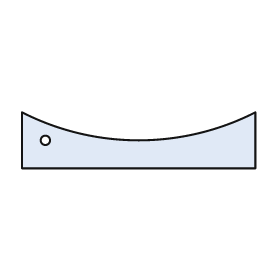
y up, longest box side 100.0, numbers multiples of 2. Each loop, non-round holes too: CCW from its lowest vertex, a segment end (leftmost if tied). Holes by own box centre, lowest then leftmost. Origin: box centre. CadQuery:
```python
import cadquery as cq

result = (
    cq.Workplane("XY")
    .moveTo(-50.0, -12.0)
    .lineTo(50.0, -12.0)
    .lineTo(50.0, 12.0)
    .threePointArc((0.0, 0.0), (-50.0, 12.0))
    .close()
    .moveTo(-40.0, 0.0)
    .circle(2.0)
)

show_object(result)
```